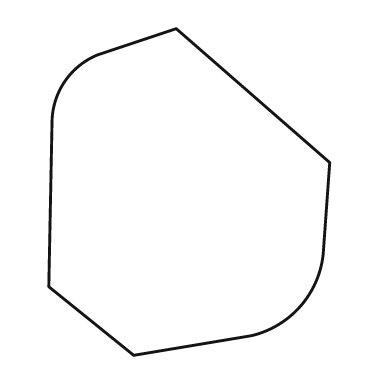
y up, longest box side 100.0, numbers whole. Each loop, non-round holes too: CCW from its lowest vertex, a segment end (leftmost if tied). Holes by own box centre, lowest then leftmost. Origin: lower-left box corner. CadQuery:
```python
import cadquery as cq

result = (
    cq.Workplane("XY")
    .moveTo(26.0, 0.0)
    .lineTo(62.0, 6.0)
    .threePointArc((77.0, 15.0), (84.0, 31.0))
    .lineTo(86.0, 59.0)
    .lineTo(39.0, 100.0)
    .lineTo(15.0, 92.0)
    .threePointArc((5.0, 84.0), (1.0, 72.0))
    .lineTo(0.0, 21.0)
    .close()
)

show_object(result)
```